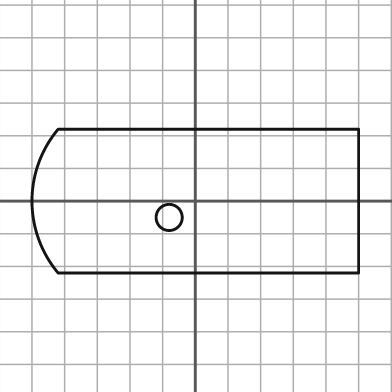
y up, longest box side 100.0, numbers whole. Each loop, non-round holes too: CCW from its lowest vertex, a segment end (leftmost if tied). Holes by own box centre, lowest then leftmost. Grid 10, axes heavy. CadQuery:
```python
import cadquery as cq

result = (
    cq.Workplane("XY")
    .moveTo(-42.0, -22.0)
    .lineTo(50.0, -22.0)
    .lineTo(50.0, 22.0)
    .lineTo(-42.0, 22.0)
    .threePointArc((-50.0, 0.0), (-42.0, -22.0))
    .close()
    .moveTo(-8.0, -5.0)
    .circle(4.0)
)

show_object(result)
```